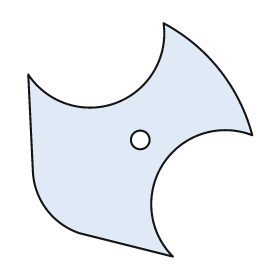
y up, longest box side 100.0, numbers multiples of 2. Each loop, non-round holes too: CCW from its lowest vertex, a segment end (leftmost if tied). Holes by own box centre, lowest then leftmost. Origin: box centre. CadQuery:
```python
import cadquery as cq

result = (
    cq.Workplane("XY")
    .moveTo(14.0, -50.0)
    .threePointArc((10.0, -10.0), (48.0, 2.0))
    .threePointArc((34.0, 30.0), (10.0, 50.0))
    .threePointArc((-10.0, 16.0), (-48.0, 28.0))
    .lineTo(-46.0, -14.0)
    .threePointArc((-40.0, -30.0), (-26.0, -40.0))
    .close()
    .moveTo(0.0, 0.0)
    .circle(4.0)
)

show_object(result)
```